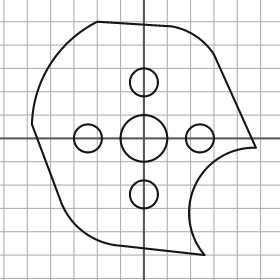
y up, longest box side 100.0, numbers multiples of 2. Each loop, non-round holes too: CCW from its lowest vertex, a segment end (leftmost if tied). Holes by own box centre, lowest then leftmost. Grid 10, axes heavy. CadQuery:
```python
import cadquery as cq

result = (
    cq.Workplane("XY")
    .moveTo(26.0, -50.0)
    .threePointArc((22.0, -20.0), (48.0, -4.0))
    .lineTo(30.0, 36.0)
    .threePointArc((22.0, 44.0), (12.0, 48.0))
    .lineTo(-20.0, 50.0)
    .threePointArc((-40.0, 32.0), (-48.0, 6.0))
    .lineTo(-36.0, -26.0)
    .threePointArc((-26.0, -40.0), (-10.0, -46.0))
    .close()
    .moveTo(0.0, -24.0)
    .circle(6.0)
    .moveTo(-24.0, 0.0)
    .circle(6.0)
    .moveTo(0.0, 0.0)
    .circle(10.0)
    .moveTo(24.0, 0.0)
    .circle(6.0)
    .moveTo(0.0, 24.0)
    .circle(6.0)
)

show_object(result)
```